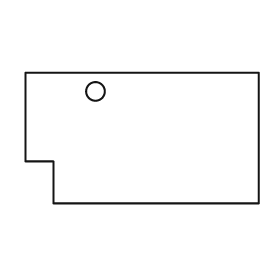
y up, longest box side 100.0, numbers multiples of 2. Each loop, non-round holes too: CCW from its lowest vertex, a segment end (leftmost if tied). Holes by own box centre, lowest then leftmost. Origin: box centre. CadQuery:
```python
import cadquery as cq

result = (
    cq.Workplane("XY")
    .moveTo(-38.0, -28.0)
    .lineTo(50.0, -28.0)
    .lineTo(50.0, 28.0)
    .lineTo(-50.0, 28.0)
    .lineTo(-50.0, -10.0)
    .lineTo(-38.0, -10.0)
    .close()
    .moveTo(-20.0, 20.0)
    .circle(4.0)
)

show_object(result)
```